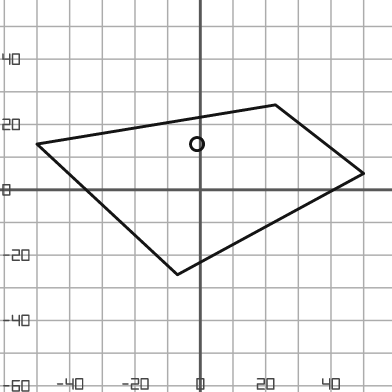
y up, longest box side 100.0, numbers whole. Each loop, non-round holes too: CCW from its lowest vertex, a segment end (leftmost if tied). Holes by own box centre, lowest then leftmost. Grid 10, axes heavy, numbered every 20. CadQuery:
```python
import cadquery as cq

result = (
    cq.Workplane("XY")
    .moveTo(-7.0, -26.0)
    .lineTo(50.0, 5.0)
    .lineTo(23.0, 26.0)
    .lineTo(-50.0, 14.0)
    .close()
    .moveTo(-1.0, 14.0)
    .circle(2.0)
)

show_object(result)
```